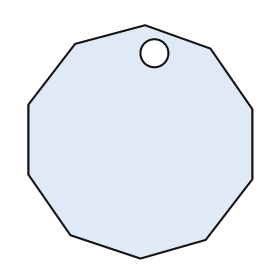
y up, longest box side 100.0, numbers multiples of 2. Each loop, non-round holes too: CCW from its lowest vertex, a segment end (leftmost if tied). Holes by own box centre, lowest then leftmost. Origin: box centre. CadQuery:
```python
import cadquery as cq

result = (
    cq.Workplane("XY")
    .moveTo(0.0, -50.0)
    .lineTo(28.0, -42.0)
    .lineTo(48.0, -16.0)
    .lineTo(48.0, 14.0)
    .lineTo(30.0, 40.0)
    .lineTo(2.0, 50.0)
    .lineTo(-28.0, 42.0)
    .lineTo(-48.0, 16.0)
    .lineTo(-48.0, -14.0)
    .lineTo(-30.0, -40.0)
    .close()
    .moveTo(6.0, 38.0)
    .circle(6.0)
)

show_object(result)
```